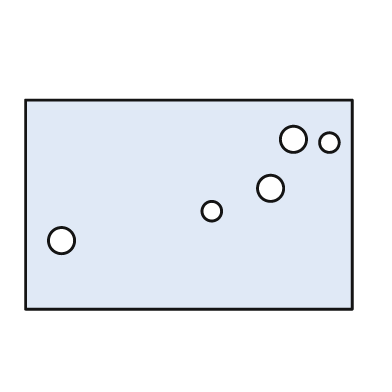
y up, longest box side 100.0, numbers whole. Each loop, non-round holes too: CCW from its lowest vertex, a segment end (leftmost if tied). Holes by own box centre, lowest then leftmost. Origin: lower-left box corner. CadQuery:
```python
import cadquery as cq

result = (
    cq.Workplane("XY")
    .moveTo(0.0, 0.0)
    .lineTo(100.0, 0.0)
    .lineTo(100.0, 64.0)
    .lineTo(0.0, 64.0)
    .close()
    .moveTo(11.0, 21.0)
    .circle(4.0)
    .moveTo(57.0, 30.0)
    .circle(3.0)
    .moveTo(75.0, 37.0)
    .circle(4.0)
    .moveTo(93.0, 51.0)
    .circle(3.0)
    .moveTo(82.0, 52.0)
    .circle(4.0)
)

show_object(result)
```